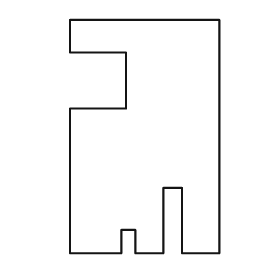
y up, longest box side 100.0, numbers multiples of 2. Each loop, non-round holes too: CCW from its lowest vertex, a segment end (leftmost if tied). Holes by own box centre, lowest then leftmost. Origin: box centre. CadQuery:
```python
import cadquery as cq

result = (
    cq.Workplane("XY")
    .moveTo(-32.0, -50.0)
    .lineTo(-10.0, -50.0)
    .lineTo(-10.0, -40.0)
    .lineTo(-4.0, -40.0)
    .lineTo(-4.0, -50.0)
    .lineTo(8.0, -50.0)
    .lineTo(8.0, -22.0)
    .lineTo(16.0, -22.0)
    .lineTo(16.0, -50.0)
    .lineTo(32.0, -50.0)
    .lineTo(32.0, 50.0)
    .lineTo(-32.0, 50.0)
    .lineTo(-32.0, 36.0)
    .lineTo(-8.0, 36.0)
    .lineTo(-8.0, 12.0)
    .lineTo(-32.0, 12.0)
    .close()
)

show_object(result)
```